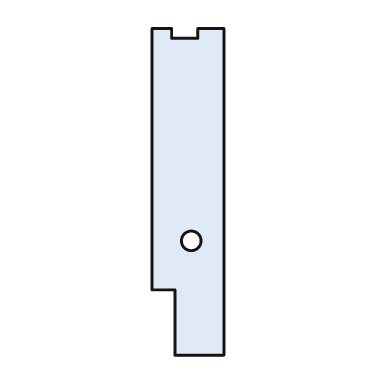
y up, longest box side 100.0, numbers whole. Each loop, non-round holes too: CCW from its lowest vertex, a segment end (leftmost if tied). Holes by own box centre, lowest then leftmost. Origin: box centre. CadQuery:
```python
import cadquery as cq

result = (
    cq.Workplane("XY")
    .moveTo(-4.0, -50.0)
    .lineTo(11.0, -50.0)
    .lineTo(11.0, 50.0)
    .lineTo(3.0, 50.0)
    .lineTo(3.0, 47.0)
    .lineTo(-5.0, 47.0)
    .lineTo(-5.0, 50.0)
    .lineTo(-11.0, 50.0)
    .lineTo(-11.0, -30.0)
    .lineTo(-4.0, -30.0)
    .close()
    .moveTo(1.0, -15.0)
    .circle(3.0)
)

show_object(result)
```